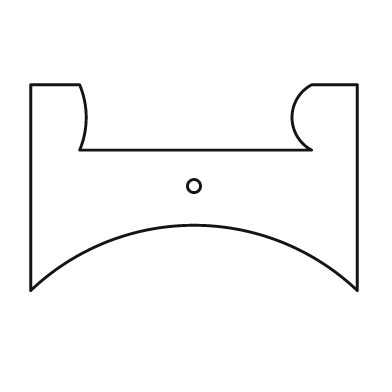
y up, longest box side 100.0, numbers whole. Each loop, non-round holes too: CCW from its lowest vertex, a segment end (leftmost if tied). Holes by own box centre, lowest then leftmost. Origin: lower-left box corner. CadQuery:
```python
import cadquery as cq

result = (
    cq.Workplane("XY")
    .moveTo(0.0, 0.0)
    .threePointArc((50.0, 20.0), (100.0, 0.0))
    .lineTo(100.0, 63.0)
    .lineTo(86.0, 63.0)
    .threePointArc((80.0, 53.0), (86.0, 43.0))
    .lineTo(15.0, 43.0)
    .threePointArc((17.0, 53.0), (15.0, 63.0))
    .lineTo(0.0, 63.0)
    .close()
    .moveTo(50.0, 32.0)
    .circle(2.0)
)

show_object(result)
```